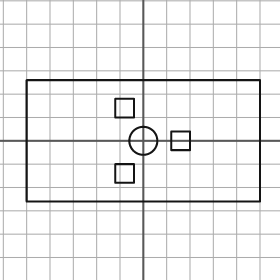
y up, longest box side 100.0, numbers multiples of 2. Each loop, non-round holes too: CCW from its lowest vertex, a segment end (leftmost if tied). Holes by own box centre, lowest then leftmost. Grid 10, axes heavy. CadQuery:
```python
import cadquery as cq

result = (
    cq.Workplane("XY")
    .moveTo(-50.0, -26.0)
    .lineTo(50.0, -26.0)
    .lineTo(50.0, 26.0)
    .lineTo(-50.0, 26.0)
    .close()
    .moveTo(-12.0, -18.0)
    .lineTo(-4.0, -18.0)
    .lineTo(-4.0, -10.0)
    .lineTo(-12.0, -10.0)
    .close()
    .moveTo(0.0, 0.0)
    .circle(6.0)
    .moveTo(12.0, -4.0)
    .lineTo(20.0, -4.0)
    .lineTo(20.0, 4.0)
    .lineTo(12.0, 4.0)
    .close()
    .moveTo(-12.0, 10.0)
    .lineTo(-4.0, 10.0)
    .lineTo(-4.0, 18.0)
    .lineTo(-12.0, 18.0)
    .close()
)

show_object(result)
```